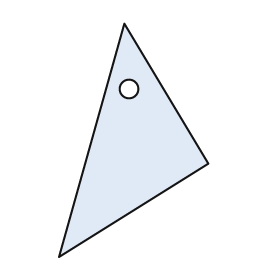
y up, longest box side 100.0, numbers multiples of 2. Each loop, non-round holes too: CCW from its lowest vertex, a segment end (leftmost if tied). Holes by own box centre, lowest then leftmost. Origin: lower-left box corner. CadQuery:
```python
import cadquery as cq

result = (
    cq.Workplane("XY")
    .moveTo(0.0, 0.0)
    .lineTo(64.0, 40.0)
    .lineTo(28.0, 100.0)
    .close()
    .moveTo(30.0, 72.0)
    .circle(4.0)
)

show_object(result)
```